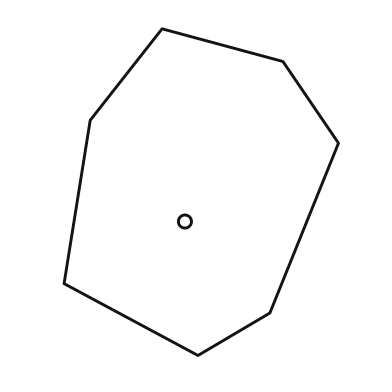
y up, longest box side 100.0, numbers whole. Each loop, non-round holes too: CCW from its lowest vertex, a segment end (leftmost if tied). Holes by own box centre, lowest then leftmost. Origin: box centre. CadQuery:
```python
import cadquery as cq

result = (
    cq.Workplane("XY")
    .moveTo(-1.0, -50.0)
    .lineTo(21.0, -37.0)
    .lineTo(42.0, 15.0)
    .lineTo(25.0, 40.0)
    .lineTo(-12.0, 50.0)
    .lineTo(-34.0, 22.0)
    .lineTo(-42.0, -28.0)
    .close()
    .moveTo(-5.0, -9.0)
    .circle(2.0)
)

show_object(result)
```